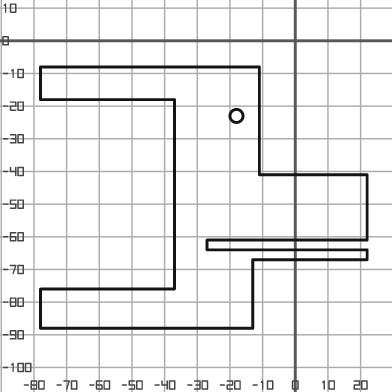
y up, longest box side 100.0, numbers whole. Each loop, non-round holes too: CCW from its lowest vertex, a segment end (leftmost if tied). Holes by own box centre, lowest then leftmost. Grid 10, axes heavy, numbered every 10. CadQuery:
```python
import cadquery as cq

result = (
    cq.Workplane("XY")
    .moveTo(-78.0, -88.0)
    .lineTo(-13.0, -88.0)
    .lineTo(-13.0, -67.0)
    .lineTo(22.0, -67.0)
    .lineTo(22.0, -64.0)
    .lineTo(-27.0, -64.0)
    .lineTo(-27.0, -61.0)
    .lineTo(22.0, -61.0)
    .lineTo(22.0, -41.0)
    .lineTo(-11.0, -41.0)
    .lineTo(-11.0, -8.0)
    .lineTo(-78.0, -8.0)
    .lineTo(-78.0, -18.0)
    .lineTo(-37.0, -18.0)
    .lineTo(-37.0, -76.0)
    .lineTo(-78.0, -76.0)
    .close()
    .moveTo(-18.0, -23.0)
    .circle(2.0)
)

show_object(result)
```